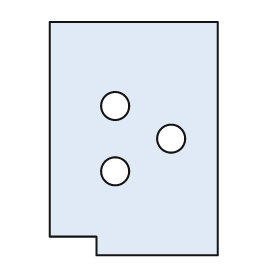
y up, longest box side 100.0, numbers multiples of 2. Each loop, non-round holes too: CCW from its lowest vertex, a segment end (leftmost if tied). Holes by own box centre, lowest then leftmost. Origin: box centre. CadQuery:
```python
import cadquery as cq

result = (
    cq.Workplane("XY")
    .moveTo(-16.0, -50.0)
    .lineTo(36.0, -50.0)
    .lineTo(36.0, 50.0)
    .lineTo(-36.0, 50.0)
    .lineTo(-36.0, -42.0)
    .lineTo(-16.0, -42.0)
    .close()
    .moveTo(-8.0, -14.0)
    .circle(6.0)
    .moveTo(16.0, 0.0)
    .circle(6.0)
    .moveTo(-8.0, 14.0)
    .circle(6.0)
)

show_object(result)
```